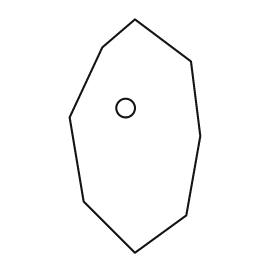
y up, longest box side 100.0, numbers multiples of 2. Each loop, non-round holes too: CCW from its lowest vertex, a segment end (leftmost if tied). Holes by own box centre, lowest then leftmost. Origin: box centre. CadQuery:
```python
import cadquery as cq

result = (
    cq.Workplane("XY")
    .moveTo(0.0, -50.0)
    .lineTo(22.0, -34.0)
    .lineTo(28.0, 0.0)
    .lineTo(24.0, 32.0)
    .lineTo(0.0, 50.0)
    .lineTo(-14.0, 38.0)
    .lineTo(-28.0, 8.0)
    .lineTo(-22.0, -28.0)
    .close()
    .moveTo(-4.0, 12.0)
    .circle(4.0)
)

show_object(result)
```